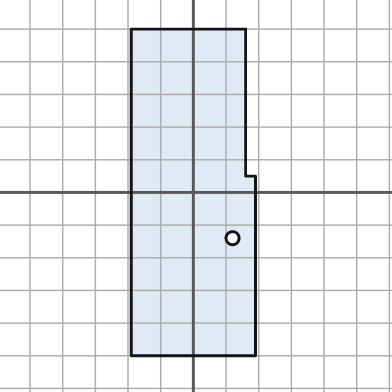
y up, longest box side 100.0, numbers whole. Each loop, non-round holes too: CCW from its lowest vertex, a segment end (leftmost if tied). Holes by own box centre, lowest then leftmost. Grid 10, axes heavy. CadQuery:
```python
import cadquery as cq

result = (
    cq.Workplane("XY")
    .moveTo(-19.0, -50.0)
    .lineTo(19.0, -50.0)
    .lineTo(19.0, 5.0)
    .lineTo(16.0, 5.0)
    .lineTo(16.0, 50.0)
    .lineTo(-19.0, 50.0)
    .close()
    .moveTo(12.0, -14.0)
    .circle(2.0)
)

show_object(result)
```